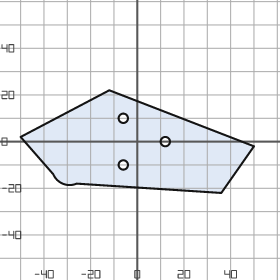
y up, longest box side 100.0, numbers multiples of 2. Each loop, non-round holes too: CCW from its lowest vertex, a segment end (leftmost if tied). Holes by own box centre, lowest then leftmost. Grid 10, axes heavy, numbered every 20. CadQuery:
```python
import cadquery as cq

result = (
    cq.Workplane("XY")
    .moveTo(36.0, -22.0)
    .lineTo(50.0, -2.0)
    .lineTo(-12.0, 22.0)
    .lineTo(-50.0, 2.0)
    .lineTo(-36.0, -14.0)
    .threePointArc((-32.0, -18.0), (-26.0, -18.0))
    .close()
    .moveTo(-6.0, -10.0)
    .circle(2.0)
    .moveTo(12.0, 0.0)
    .circle(2.0)
    .moveTo(-6.0, 10.0)
    .circle(2.0)
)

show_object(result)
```